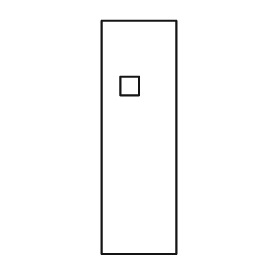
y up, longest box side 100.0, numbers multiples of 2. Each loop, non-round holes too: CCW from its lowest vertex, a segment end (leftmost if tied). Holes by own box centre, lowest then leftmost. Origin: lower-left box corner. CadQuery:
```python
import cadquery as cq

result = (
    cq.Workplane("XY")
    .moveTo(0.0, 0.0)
    .lineTo(32.0, 0.0)
    .lineTo(32.0, 100.0)
    .lineTo(0.0, 100.0)
    .close()
    .moveTo(8.0, 68.0)
    .lineTo(16.0, 68.0)
    .lineTo(16.0, 76.0)
    .lineTo(8.0, 76.0)
    .close()
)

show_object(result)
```